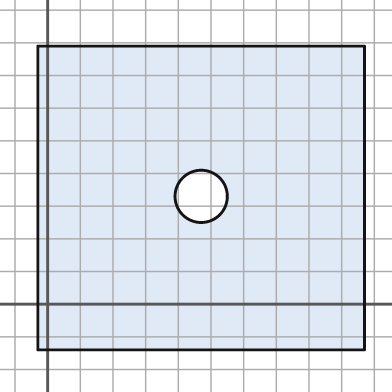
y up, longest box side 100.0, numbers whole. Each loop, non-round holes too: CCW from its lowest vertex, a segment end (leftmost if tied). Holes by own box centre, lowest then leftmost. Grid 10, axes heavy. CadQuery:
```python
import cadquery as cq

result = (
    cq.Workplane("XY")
    .moveTo(-3.0, -14.0)
    .lineTo(97.0, -14.0)
    .lineTo(97.0, 79.0)
    .lineTo(-3.0, 79.0)
    .close()
    .moveTo(47.0, 33.0)
    .circle(8.0)
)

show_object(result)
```